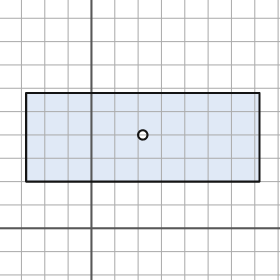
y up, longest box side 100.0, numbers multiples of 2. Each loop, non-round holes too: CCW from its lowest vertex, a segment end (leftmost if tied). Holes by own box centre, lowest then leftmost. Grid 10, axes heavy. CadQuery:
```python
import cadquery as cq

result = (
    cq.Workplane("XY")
    .moveTo(-28.0, 20.0)
    .lineTo(72.0, 20.0)
    .lineTo(72.0, 58.0)
    .lineTo(-28.0, 58.0)
    .close()
    .moveTo(22.0, 40.0)
    .circle(2.0)
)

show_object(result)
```